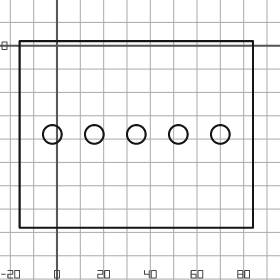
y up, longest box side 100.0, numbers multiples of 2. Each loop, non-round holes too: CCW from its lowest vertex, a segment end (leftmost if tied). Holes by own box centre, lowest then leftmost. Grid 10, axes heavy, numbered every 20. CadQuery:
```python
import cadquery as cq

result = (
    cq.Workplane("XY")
    .moveTo(-16.0, -78.0)
    .lineTo(84.0, -78.0)
    .lineTo(84.0, 2.0)
    .lineTo(-16.0, 2.0)
    .close()
    .moveTo(-2.0, -38.0)
    .circle(4.0)
    .moveTo(16.0, -38.0)
    .circle(4.0)
    .moveTo(34.0, -38.0)
    .circle(4.0)
    .moveTo(52.0, -38.0)
    .circle(4.0)
    .moveTo(70.0, -38.0)
    .circle(4.0)
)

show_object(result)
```